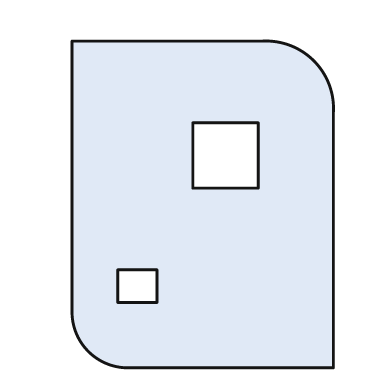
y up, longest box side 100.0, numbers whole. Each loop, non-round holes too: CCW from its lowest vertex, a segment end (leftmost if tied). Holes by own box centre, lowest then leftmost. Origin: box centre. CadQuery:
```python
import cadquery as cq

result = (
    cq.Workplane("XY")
    .moveTo(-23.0, -50.0)
    .lineTo(40.0, -50.0)
    .lineTo(40.0, 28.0)
    .threePointArc((34.0, 44.0), (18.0, 50.0))
    .lineTo(-40.0, 50.0)
    .lineTo(-40.0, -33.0)
    .threePointArc((-35.0, -45.0), (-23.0, -50.0))
    .close()
    .moveTo(-26.0, -30.0)
    .lineTo(-14.0, -30.0)
    .lineTo(-14.0, -20.0)
    .lineTo(-26.0, -20.0)
    .close()
    .moveTo(-3.0, 5.0)
    .lineTo(17.0, 5.0)
    .lineTo(17.0, 25.0)
    .lineTo(-3.0, 25.0)
    .close()
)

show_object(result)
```